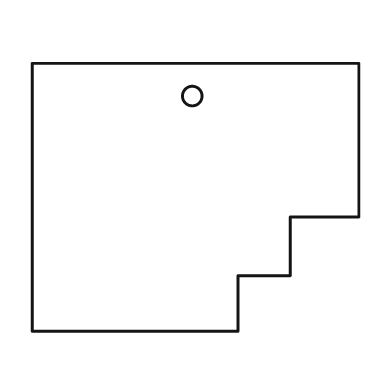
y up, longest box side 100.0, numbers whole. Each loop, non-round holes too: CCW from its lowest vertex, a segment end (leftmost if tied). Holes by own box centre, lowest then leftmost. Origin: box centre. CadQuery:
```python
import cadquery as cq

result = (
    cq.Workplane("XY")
    .moveTo(-50.0, -41.0)
    .lineTo(13.0, -41.0)
    .lineTo(13.0, -24.0)
    .lineTo(29.0, -24.0)
    .lineTo(29.0, -6.0)
    .lineTo(50.0, -6.0)
    .lineTo(50.0, 41.0)
    .lineTo(-50.0, 41.0)
    .close()
    .moveTo(-1.0, 31.0)
    .circle(3.0)
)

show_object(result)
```